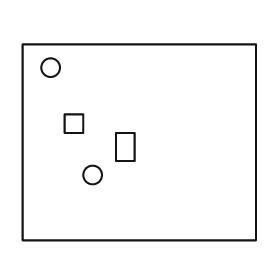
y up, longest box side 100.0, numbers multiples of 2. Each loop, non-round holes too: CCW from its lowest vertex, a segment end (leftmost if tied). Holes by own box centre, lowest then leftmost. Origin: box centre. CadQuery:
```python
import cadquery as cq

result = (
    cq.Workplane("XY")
    .moveTo(-50.0, -42.0)
    .lineTo(50.0, -42.0)
    .lineTo(50.0, 42.0)
    .lineTo(-50.0, 42.0)
    .close()
    .moveTo(-20.0, -14.0)
    .circle(4.0)
    .moveTo(-10.0, -8.0)
    .lineTo(-2.0, -8.0)
    .lineTo(-2.0, 4.0)
    .lineTo(-10.0, 4.0)
    .close()
    .moveTo(-32.0, 4.0)
    .lineTo(-24.0, 4.0)
    .lineTo(-24.0, 12.0)
    .lineTo(-32.0, 12.0)
    .close()
    .moveTo(-38.0, 32.0)
    .circle(4.0)
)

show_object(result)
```